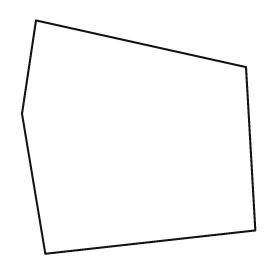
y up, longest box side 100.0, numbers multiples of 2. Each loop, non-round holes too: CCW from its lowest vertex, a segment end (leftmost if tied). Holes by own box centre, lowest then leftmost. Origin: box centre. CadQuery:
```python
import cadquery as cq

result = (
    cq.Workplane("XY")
    .moveTo(-40.0, -50.0)
    .lineTo(50.0, -40.0)
    .lineTo(46.0, 30.0)
    .lineTo(-44.0, 50.0)
    .lineTo(-50.0, 10.0)
    .close()
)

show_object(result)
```